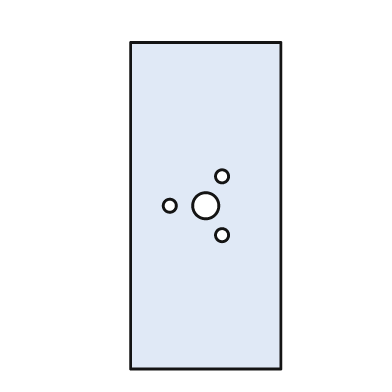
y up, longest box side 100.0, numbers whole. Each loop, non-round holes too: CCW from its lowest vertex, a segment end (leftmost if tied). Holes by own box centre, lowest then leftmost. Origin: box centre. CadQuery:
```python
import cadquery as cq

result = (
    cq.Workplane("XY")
    .moveTo(-23.0, -50.0)
    .lineTo(23.0, -50.0)
    .lineTo(23.0, 50.0)
    .lineTo(-23.0, 50.0)
    .close()
    .moveTo(5.0, -9.0)
    .circle(2.0)
    .moveTo(-11.0, 0.0)
    .circle(2.0)
    .moveTo(0.0, 0.0)
    .circle(4.0)
    .moveTo(5.0, 9.0)
    .circle(2.0)
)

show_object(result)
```